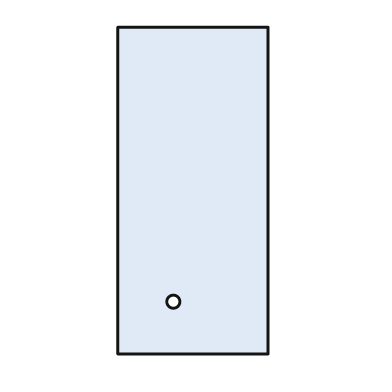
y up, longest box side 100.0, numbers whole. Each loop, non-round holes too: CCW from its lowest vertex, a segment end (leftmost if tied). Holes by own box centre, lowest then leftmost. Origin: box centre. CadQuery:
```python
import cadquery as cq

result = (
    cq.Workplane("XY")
    .moveTo(-23.0, -50.0)
    .lineTo(23.0, -50.0)
    .lineTo(23.0, 50.0)
    .lineTo(-23.0, 50.0)
    .close()
    .moveTo(-6.0, -34.0)
    .circle(2.0)
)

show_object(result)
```